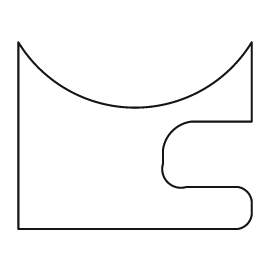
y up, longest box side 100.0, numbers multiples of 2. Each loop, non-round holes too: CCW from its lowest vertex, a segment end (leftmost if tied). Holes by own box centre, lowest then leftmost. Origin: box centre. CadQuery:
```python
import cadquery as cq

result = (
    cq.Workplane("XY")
    .moveTo(-50.0, -40.0)
    .lineTo(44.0, -40.0)
    .threePointArc((48.0, -38.0), (50.0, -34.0))
    .lineTo(50.0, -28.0)
    .threePointArc((48.0, -24.0), (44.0, -22.0))
    .lineTo(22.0, -22.0)
    .threePointArc((14.0, -20.0), (12.0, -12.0))
    .lineTo(12.0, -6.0)
    .threePointArc((16.0, 2.0), (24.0, 6.0))
    .lineTo(50.0, 6.0)
    .lineTo(50.0, 40.0)
    .threePointArc((0.0, 12.0), (-50.0, 40.0))
    .close()
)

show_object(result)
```